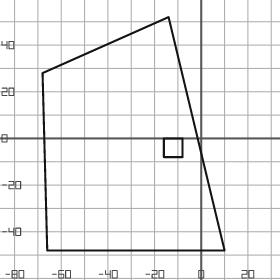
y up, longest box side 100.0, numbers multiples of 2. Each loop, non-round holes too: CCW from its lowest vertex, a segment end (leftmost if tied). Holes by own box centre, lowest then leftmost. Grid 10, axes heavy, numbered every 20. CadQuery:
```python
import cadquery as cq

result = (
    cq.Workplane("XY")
    .moveTo(-66.0, -48.0)
    .lineTo(10.0, -48.0)
    .lineTo(-14.0, 52.0)
    .lineTo(-68.0, 28.0)
    .close()
    .moveTo(-16.0, -8.0)
    .lineTo(-8.0, -8.0)
    .lineTo(-8.0, 0.0)
    .lineTo(-16.0, 0.0)
    .close()
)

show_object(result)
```